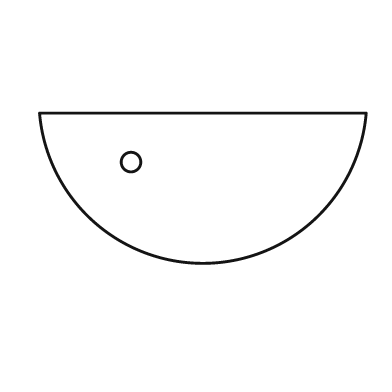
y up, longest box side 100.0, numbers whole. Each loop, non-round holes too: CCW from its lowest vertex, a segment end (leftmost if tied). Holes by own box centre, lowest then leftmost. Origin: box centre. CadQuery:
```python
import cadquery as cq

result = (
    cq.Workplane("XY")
    .moveTo(-50.0, 23.0)
    .threePointArc((0.0, -23.0), (50.0, 23.0))
    .close()
    .moveTo(-22.0, 8.0)
    .circle(3.0)
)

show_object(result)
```